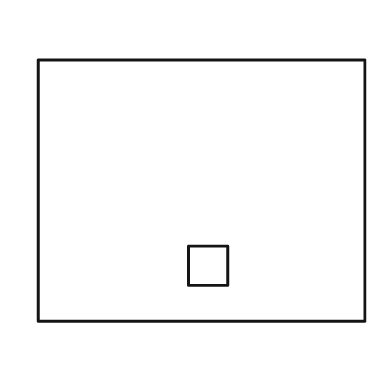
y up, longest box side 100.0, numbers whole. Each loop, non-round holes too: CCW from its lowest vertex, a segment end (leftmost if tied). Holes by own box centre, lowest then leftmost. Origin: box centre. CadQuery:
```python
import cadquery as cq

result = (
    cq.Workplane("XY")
    .moveTo(-50.0, -40.0)
    .lineTo(50.0, -40.0)
    .lineTo(50.0, 40.0)
    .lineTo(-50.0, 40.0)
    .close()
    .moveTo(-4.0, -29.0)
    .lineTo(8.0, -29.0)
    .lineTo(8.0, -17.0)
    .lineTo(-4.0, -17.0)
    .close()
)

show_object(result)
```